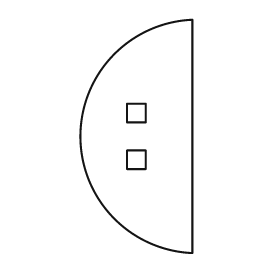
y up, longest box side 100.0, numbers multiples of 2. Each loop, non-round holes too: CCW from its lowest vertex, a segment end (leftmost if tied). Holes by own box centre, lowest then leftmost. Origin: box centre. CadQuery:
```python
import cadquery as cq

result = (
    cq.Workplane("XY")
    .moveTo(24.0, -50.0)
    .lineTo(24.0, 50.0)
    .threePointArc((-24.0, 0.0), (24.0, -50.0))
    .close()
    .moveTo(-4.0, -14.0)
    .lineTo(4.0, -14.0)
    .lineTo(4.0, -6.0)
    .lineTo(-4.0, -6.0)
    .close()
    .moveTo(-4.0, 6.0)
    .lineTo(4.0, 6.0)
    .lineTo(4.0, 14.0)
    .lineTo(-4.0, 14.0)
    .close()
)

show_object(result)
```